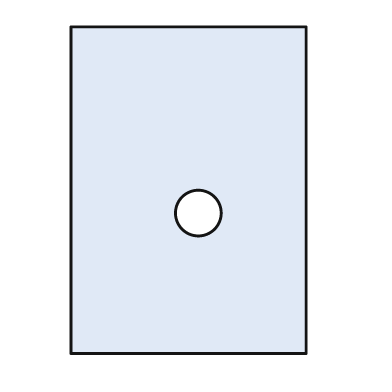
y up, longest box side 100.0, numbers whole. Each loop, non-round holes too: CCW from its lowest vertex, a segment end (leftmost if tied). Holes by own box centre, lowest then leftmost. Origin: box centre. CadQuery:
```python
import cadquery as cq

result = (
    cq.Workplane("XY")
    .moveTo(-36.0, -50.0)
    .lineTo(36.0, -50.0)
    .lineTo(36.0, 50.0)
    .lineTo(-36.0, 50.0)
    .close()
    .moveTo(3.0, -7.0)
    .circle(7.0)
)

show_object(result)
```